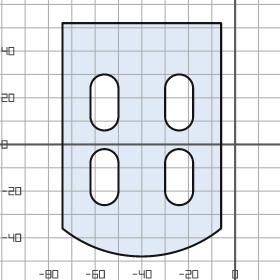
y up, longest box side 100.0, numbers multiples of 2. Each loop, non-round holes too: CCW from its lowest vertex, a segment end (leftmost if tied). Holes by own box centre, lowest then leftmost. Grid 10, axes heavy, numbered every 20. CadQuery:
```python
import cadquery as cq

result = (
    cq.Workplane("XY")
    .moveTo(-74.0, -36.0)
    .threePointArc((-40.0, -48.0), (-6.0, -36.0))
    .lineTo(-6.0, 52.0)
    .lineTo(-74.0, 52.0)
    .close()
    .moveTo(-62.0, -20.0)
    .threePointArc((-56.0, -26.0), (-50.0, -20.0))
    .lineTo(-50.0, -8.0)
    .threePointArc((-56.0, -2.0), (-62.0, -8.0))
    .close()
    .moveTo(-30.0, -20.0)
    .threePointArc((-24.0, -26.0), (-18.0, -20.0))
    .lineTo(-18.0, -8.0)
    .threePointArc((-24.0, -2.0), (-30.0, -8.0))
    .close()
    .moveTo(-62.0, 12.0)
    .threePointArc((-56.0, 6.0), (-50.0, 12.0))
    .lineTo(-50.0, 24.0)
    .threePointArc((-56.0, 30.0), (-62.0, 24.0))
    .close()
    .moveTo(-30.0, 12.0)
    .threePointArc((-24.0, 6.0), (-18.0, 12.0))
    .lineTo(-18.0, 24.0)
    .threePointArc((-24.0, 30.0), (-30.0, 24.0))
    .close()
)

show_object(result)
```